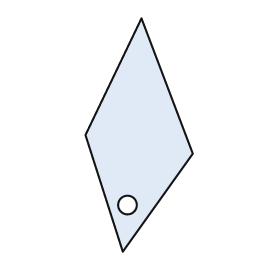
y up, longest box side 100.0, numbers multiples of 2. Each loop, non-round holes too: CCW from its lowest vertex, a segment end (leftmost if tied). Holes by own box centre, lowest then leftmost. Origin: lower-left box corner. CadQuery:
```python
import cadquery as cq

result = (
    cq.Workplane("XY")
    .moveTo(16.0, 0.0)
    .lineTo(46.0, 42.0)
    .lineTo(24.0, 100.0)
    .lineTo(0.0, 50.0)
    .close()
    .moveTo(18.0, 20.0)
    .circle(4.0)
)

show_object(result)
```